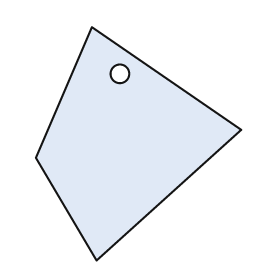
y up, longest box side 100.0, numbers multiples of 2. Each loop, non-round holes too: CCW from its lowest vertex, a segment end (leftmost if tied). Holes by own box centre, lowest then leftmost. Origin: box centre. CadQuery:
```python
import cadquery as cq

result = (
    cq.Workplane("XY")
    .moveTo(-18.0, -50.0)
    .lineTo(44.0, 6.0)
    .lineTo(-20.0, 50.0)
    .lineTo(-44.0, -6.0)
    .close()
    .moveTo(-8.0, 30.0)
    .circle(4.0)
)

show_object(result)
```